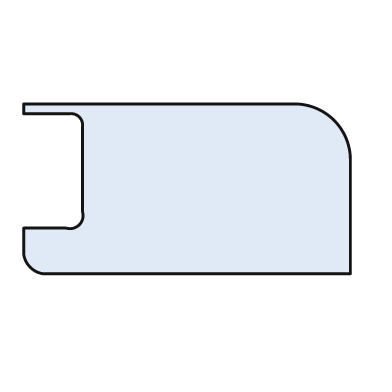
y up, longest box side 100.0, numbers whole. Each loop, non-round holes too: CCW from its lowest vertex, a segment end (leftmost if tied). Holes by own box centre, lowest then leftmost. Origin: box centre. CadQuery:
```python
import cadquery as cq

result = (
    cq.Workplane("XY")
    .moveTo(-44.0, -26.0)
    .lineTo(50.0, -26.0)
    .lineTo(50.0, 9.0)
    .threePointArc((45.0, 21.0), (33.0, 26.0))
    .lineTo(-50.0, 26.0)
    .lineTo(-50.0, 23.0)
    .lineTo(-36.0, 23.0)
    .threePointArc((-33.0, 22.0), (-32.0, 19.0))
    .lineTo(-32.0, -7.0)
    .threePointArc((-33.0, -11.0), (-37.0, -12.0))
    .lineTo(-50.0, -12.0)
    .lineTo(-50.0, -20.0)
    .threePointArc((-48.0, -24.0), (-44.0, -26.0))
    .close()
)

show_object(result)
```